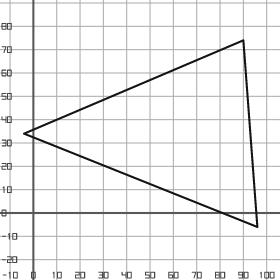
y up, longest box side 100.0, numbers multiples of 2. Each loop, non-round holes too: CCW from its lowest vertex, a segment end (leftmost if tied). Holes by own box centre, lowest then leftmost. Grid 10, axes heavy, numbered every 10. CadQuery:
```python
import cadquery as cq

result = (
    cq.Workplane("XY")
    .moveTo(96.0, -6.0)
    .lineTo(90.0, 74.0)
    .lineTo(-4.0, 34.0)
    .close()
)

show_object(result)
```